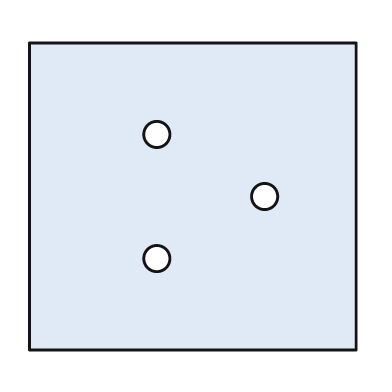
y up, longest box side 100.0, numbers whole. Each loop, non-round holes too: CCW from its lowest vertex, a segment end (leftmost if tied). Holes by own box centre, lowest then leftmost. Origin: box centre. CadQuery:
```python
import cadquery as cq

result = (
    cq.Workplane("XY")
    .moveTo(-50.0, -47.0)
    .lineTo(50.0, -47.0)
    .lineTo(50.0, 47.0)
    .lineTo(-50.0, 47.0)
    .close()
    .moveTo(-11.0, -19.0)
    .circle(4.0)
    .moveTo(22.0, 0.0)
    .circle(4.0)
    .moveTo(-11.0, 19.0)
    .circle(4.0)
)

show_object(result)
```